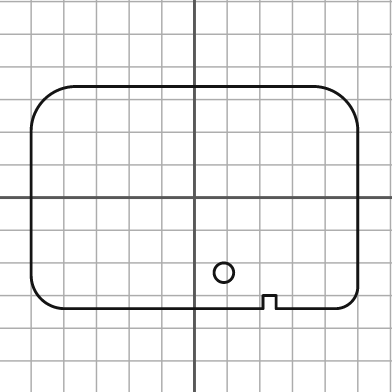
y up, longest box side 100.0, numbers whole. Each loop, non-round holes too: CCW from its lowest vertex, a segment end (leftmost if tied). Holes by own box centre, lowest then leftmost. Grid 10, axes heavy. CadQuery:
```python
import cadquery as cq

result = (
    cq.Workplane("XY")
    .moveTo(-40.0, -34.0)
    .lineTo(21.0, -34.0)
    .lineTo(21.0, -30.0)
    .lineTo(25.0, -30.0)
    .lineTo(25.0, -34.0)
    .lineTo(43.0, -34.0)
    .threePointArc((48.0, -32.0), (50.0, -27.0))
    .lineTo(50.0, 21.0)
    .threePointArc((46.0, 30.0), (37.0, 34.0))
    .lineTo(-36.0, 34.0)
    .threePointArc((-46.0, 30.0), (-50.0, 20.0))
    .lineTo(-50.0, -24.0)
    .threePointArc((-47.0, -31.0), (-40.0, -34.0))
    .close()
    .moveTo(9.0, -23.0)
    .circle(3.0)
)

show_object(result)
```